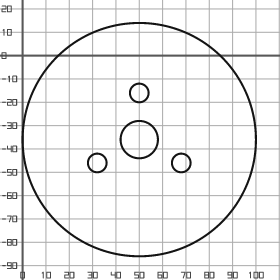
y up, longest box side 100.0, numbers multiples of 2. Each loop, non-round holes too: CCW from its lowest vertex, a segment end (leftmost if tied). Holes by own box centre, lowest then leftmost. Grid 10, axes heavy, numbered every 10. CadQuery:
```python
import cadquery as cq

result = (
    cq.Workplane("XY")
    .moveTo(50.0, -36.0)
    .circle(50.0)
    .moveTo(32.0, -46.0)
    .circle(4.0)
    .moveTo(68.0, -46.0)
    .circle(4.0)
    .moveTo(50.0, -36.0)
    .circle(8.0)
    .moveTo(50.0, -16.0)
    .circle(4.0)
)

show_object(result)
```